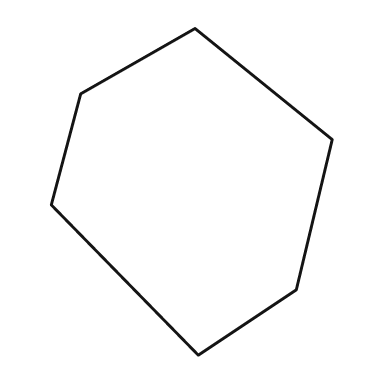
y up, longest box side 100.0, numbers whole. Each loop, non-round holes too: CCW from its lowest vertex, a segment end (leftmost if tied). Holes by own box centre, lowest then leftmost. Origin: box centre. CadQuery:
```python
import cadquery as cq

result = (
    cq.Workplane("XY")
    .moveTo(2.0, -50.0)
    .lineTo(32.0, -30.0)
    .lineTo(43.0, 16.0)
    .lineTo(1.0, 50.0)
    .lineTo(-34.0, 30.0)
    .lineTo(-43.0, -4.0)
    .close()
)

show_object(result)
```